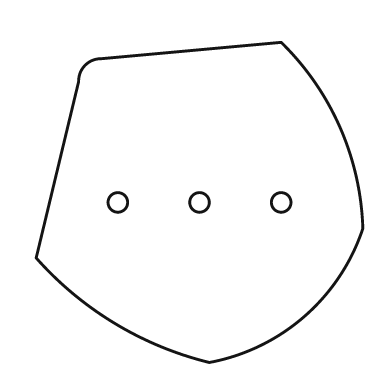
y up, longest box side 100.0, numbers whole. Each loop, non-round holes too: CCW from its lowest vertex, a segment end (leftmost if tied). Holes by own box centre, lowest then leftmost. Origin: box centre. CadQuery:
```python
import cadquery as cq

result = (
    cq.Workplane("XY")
    .moveTo(3.0, -49.0)
    .threePointArc((32.0, -35.0), (50.0, -8.0))
    .threePointArc((43.0, 23.0), (25.0, 49.0))
    .lineTo(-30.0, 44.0)
    .threePointArc((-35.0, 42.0), (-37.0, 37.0))
    .lineTo(-50.0, -17.0)
    .threePointArc((-26.0, -37.0), (3.0, -49.0))
    .close()
    .moveTo(-25.0, 0.0)
    .circle(3.0)
    .moveTo(0.0, 0.0)
    .circle(3.0)
    .moveTo(25.0, 0.0)
    .circle(3.0)
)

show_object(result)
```